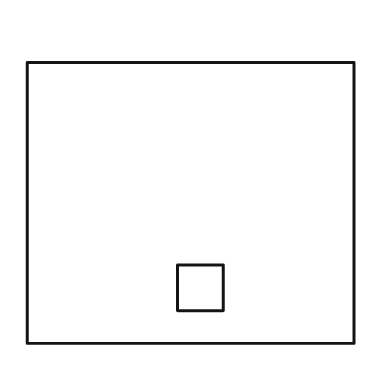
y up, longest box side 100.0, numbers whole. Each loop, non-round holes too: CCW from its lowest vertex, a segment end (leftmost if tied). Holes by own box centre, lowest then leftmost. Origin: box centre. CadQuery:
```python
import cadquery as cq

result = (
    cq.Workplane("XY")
    .moveTo(-50.0, -43.0)
    .lineTo(50.0, -43.0)
    .lineTo(50.0, 43.0)
    .lineTo(-50.0, 43.0)
    .close()
    .moveTo(-4.0, -33.0)
    .lineTo(10.0, -33.0)
    .lineTo(10.0, -19.0)
    .lineTo(-4.0, -19.0)
    .close()
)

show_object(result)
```